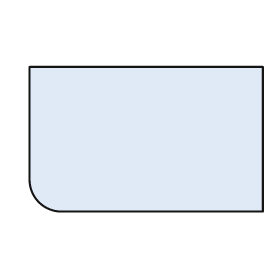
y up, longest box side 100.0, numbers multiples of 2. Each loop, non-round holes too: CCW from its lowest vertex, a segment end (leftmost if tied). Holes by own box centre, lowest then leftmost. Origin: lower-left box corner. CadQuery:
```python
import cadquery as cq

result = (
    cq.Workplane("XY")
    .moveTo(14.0, 0.0)
    .lineTo(100.0, 0.0)
    .lineTo(100.0, 62.0)
    .lineTo(0.0, 62.0)
    .lineTo(0.0, 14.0)
    .threePointArc((4.0, 4.0), (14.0, 0.0))
    .close()
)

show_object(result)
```